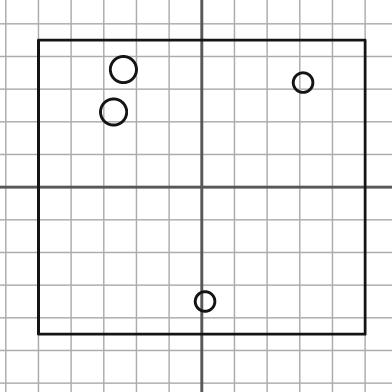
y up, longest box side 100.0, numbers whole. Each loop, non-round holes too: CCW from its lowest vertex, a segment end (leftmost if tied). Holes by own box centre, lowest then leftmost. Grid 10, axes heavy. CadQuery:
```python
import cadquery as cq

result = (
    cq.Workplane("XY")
    .moveTo(-50.0, -45.0)
    .lineTo(50.0, -45.0)
    .lineTo(50.0, 45.0)
    .lineTo(-50.0, 45.0)
    .close()
    .moveTo(1.0, -35.0)
    .circle(3.0)
    .moveTo(-27.0, 23.0)
    .circle(4.0)
    .moveTo(31.0, 32.0)
    .circle(3.0)
    .moveTo(-24.0, 36.0)
    .circle(4.0)
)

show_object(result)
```